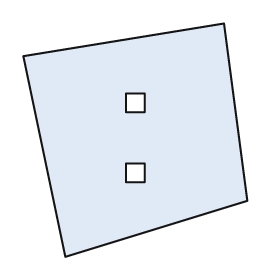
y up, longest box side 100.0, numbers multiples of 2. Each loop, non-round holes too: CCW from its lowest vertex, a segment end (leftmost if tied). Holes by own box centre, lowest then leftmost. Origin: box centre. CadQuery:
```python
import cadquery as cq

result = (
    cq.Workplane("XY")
    .moveTo(-30.0, -50.0)
    .lineTo(48.0, -26.0)
    .lineTo(38.0, 50.0)
    .lineTo(-48.0, 36.0)
    .close()
    .moveTo(-4.0, -18.0)
    .lineTo(4.0, -18.0)
    .lineTo(4.0, -10.0)
    .lineTo(-4.0, -10.0)
    .close()
    .moveTo(-4.0, 12.0)
    .lineTo(4.0, 12.0)
    .lineTo(4.0, 20.0)
    .lineTo(-4.0, 20.0)
    .close()
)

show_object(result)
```